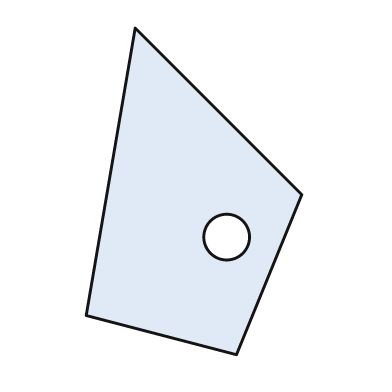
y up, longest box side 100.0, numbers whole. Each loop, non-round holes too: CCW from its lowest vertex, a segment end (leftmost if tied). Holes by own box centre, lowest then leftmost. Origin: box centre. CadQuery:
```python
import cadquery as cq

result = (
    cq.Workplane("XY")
    .moveTo(13.0, -50.0)
    .lineTo(33.0, -1.0)
    .lineTo(-18.0, 50.0)
    .lineTo(-33.0, -38.0)
    .close()
    .moveTo(10.0, -14.0)
    .circle(7.0)
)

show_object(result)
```